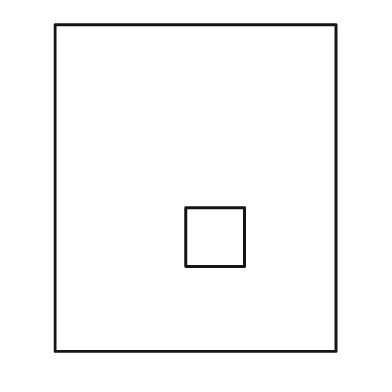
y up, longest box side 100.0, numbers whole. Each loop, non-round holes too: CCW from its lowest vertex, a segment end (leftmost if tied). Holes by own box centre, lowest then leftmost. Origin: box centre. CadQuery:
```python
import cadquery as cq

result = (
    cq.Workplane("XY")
    .moveTo(-43.0, -50.0)
    .lineTo(43.0, -50.0)
    .lineTo(43.0, 50.0)
    .lineTo(-43.0, 50.0)
    .close()
    .moveTo(-3.0, -24.0)
    .lineTo(15.0, -24.0)
    .lineTo(15.0, -6.0)
    .lineTo(-3.0, -6.0)
    .close()
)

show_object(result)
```